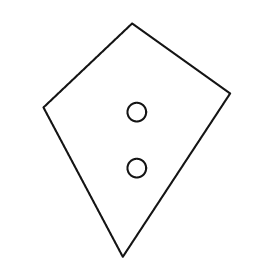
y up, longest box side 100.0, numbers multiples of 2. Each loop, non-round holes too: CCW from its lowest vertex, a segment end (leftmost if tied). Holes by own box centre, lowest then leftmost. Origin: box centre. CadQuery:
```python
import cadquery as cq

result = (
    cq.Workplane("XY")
    .moveTo(-6.0, -50.0)
    .lineTo(40.0, 20.0)
    .lineTo(-2.0, 50.0)
    .lineTo(-40.0, 14.0)
    .close()
    .moveTo(0.0, -12.0)
    .circle(4.0)
    .moveTo(0.0, 12.0)
    .circle(4.0)
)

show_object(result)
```